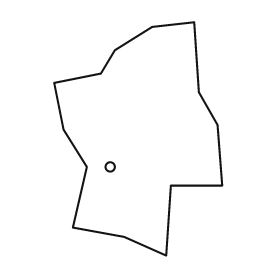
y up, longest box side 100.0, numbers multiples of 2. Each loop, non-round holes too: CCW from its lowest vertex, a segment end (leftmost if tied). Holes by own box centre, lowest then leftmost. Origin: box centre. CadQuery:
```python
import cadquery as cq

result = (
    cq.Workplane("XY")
    .moveTo(12.0, -50.0)
    .lineTo(14.0, -20.0)
    .lineTo(36.0, -20.0)
    .lineTo(34.0, 6.0)
    .lineTo(26.0, 20.0)
    .lineTo(24.0, 50.0)
    .lineTo(6.0, 48.0)
    .lineTo(-10.0, 38.0)
    .lineTo(-16.0, 28.0)
    .lineTo(-36.0, 24.0)
    .lineTo(-32.0, 4.0)
    .lineTo(-22.0, -12.0)
    .lineTo(-28.0, -38.0)
    .lineTo(-6.0, -42.0)
    .close()
    .moveTo(-12.0, -12.0)
    .circle(2.0)
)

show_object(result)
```